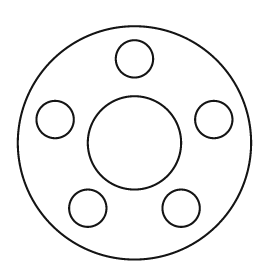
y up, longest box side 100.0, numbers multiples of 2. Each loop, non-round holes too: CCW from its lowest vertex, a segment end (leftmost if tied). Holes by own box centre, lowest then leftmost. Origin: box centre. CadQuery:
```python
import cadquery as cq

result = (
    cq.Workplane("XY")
    .moveTo(0.0, 0.0)
    .circle(50.0)
    .moveTo(-20.0, -28.0)
    .circle(8.0)
    .moveTo(20.0, -28.0)
    .circle(8.0)
    .moveTo(0.0, 0.0)
    .circle(20.0)
    .moveTo(-34.0, 10.0)
    .circle(8.0)
    .moveTo(34.0, 10.0)
    .circle(8.0)
    .moveTo(0.0, 36.0)
    .circle(8.0)
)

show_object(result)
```